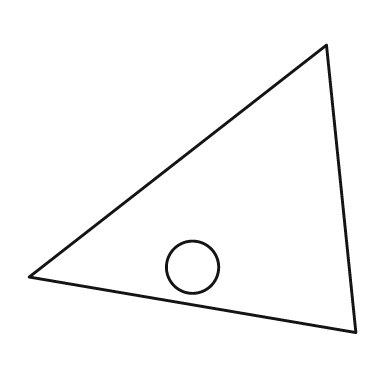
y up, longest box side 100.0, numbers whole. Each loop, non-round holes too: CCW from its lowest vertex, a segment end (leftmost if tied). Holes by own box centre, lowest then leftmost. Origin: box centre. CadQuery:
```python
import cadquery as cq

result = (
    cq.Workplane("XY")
    .moveTo(50.0, -44.0)
    .lineTo(41.0, 44.0)
    .lineTo(-50.0, -27.0)
    .close()
    .moveTo(0.0, -24.0)
    .circle(8.0)
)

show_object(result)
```